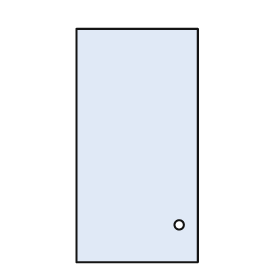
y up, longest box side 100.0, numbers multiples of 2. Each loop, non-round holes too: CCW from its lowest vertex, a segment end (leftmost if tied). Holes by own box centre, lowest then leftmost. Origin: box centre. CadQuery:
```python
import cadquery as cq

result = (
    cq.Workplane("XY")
    .moveTo(-26.0, -50.0)
    .lineTo(26.0, -50.0)
    .lineTo(26.0, 50.0)
    .lineTo(-26.0, 50.0)
    .close()
    .moveTo(18.0, -34.0)
    .circle(2.0)
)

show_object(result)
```